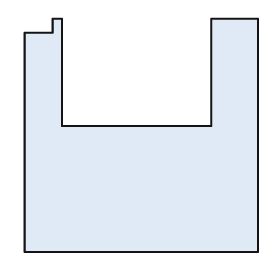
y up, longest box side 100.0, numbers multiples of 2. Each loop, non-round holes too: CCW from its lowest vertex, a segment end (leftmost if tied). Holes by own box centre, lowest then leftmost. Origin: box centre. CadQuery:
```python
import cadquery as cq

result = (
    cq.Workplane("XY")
    .moveTo(-50.0, -50.0)
    .lineTo(50.0, -50.0)
    .lineTo(50.0, 50.0)
    .lineTo(30.0, 50.0)
    .lineTo(30.0, 4.0)
    .lineTo(-34.0, 4.0)
    .lineTo(-34.0, 50.0)
    .lineTo(-38.0, 50.0)
    .lineTo(-38.0, 44.0)
    .lineTo(-50.0, 44.0)
    .close()
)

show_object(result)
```